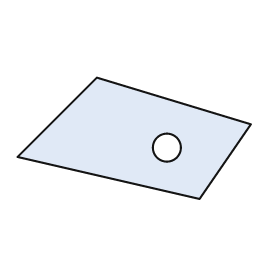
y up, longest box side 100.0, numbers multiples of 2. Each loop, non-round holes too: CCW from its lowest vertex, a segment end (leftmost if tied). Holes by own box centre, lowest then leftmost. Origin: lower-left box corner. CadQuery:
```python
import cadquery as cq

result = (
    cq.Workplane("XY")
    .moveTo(78.0, 0.0)
    .lineTo(100.0, 32.0)
    .lineTo(34.0, 52.0)
    .lineTo(0.0, 18.0)
    .close()
    .moveTo(64.0, 22.0)
    .circle(6.0)
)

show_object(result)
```